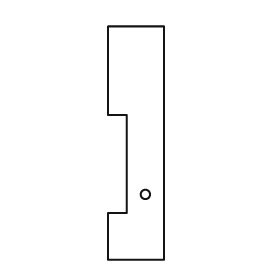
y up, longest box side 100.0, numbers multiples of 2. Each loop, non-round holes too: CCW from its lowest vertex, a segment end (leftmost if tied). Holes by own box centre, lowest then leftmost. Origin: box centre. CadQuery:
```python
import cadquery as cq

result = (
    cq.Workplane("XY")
    .moveTo(-12.0, -50.0)
    .lineTo(12.0, -50.0)
    .lineTo(12.0, 50.0)
    .lineTo(-12.0, 50.0)
    .lineTo(-12.0, 12.0)
    .lineTo(-4.0, 12.0)
    .lineTo(-4.0, -30.0)
    .lineTo(-12.0, -30.0)
    .close()
    .moveTo(4.0, -22.0)
    .circle(2.0)
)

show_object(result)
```